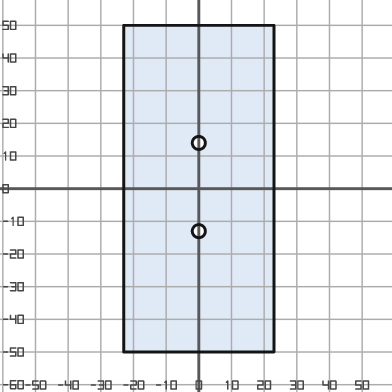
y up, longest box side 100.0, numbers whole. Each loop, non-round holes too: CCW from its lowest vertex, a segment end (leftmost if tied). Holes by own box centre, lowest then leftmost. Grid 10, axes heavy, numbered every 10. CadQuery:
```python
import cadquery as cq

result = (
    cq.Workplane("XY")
    .moveTo(-23.0, -50.0)
    .lineTo(23.0, -50.0)
    .lineTo(23.0, 50.0)
    .lineTo(-23.0, 50.0)
    .close()
    .moveTo(0.0, -13.0)
    .circle(2.0)
    .moveTo(0.0, 14.0)
    .circle(2.0)
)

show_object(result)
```